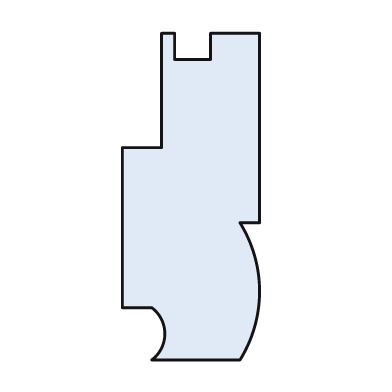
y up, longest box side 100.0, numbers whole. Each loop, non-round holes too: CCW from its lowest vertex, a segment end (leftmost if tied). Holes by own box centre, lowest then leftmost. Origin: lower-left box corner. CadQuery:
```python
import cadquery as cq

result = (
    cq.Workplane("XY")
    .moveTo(9.0, 0.0)
    .lineTo(36.0, 0.0)
    .threePointArc((42.0, 21.0), (36.0, 42.0))
    .lineTo(42.0, 42.0)
    .lineTo(42.0, 100.0)
    .lineTo(27.0, 100.0)
    .lineTo(27.0, 92.0)
    .lineTo(16.0, 92.0)
    .lineTo(16.0, 100.0)
    .lineTo(12.0, 100.0)
    .lineTo(12.0, 65.0)
    .lineTo(0.0, 65.0)
    .lineTo(0.0, 16.0)
    .lineTo(9.0, 16.0)
    .threePointArc((13.0, 8.0), (9.0, 0.0))
    .close()
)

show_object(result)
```